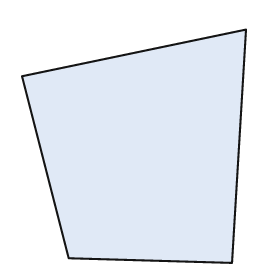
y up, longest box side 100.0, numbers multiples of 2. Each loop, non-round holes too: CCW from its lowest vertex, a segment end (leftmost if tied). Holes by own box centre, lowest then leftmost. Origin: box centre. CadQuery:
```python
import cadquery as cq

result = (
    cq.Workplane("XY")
    .moveTo(42.0, -50.0)
    .lineTo(48.0, 50.0)
    .lineTo(-48.0, 30.0)
    .lineTo(-28.0, -48.0)
    .close()
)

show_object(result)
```